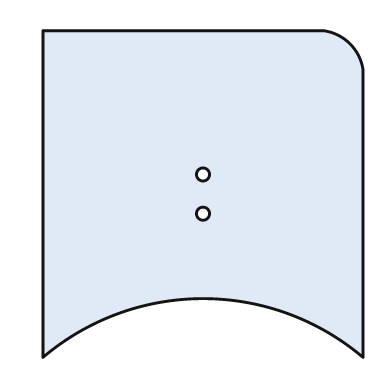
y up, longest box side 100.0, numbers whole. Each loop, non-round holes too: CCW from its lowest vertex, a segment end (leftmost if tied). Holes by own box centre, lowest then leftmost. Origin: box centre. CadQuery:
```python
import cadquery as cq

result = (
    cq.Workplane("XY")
    .moveTo(-49.0, -50.0)
    .threePointArc((0.0, -32.0), (49.0, -50.0))
    .lineTo(49.0, 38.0)
    .threePointArc((45.0, 46.0), (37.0, 50.0))
    .lineTo(-49.0, 50.0)
    .close()
    .moveTo(0.0, -6.0)
    .circle(2.0)
    .moveTo(0.0, 6.0)
    .circle(2.0)
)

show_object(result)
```